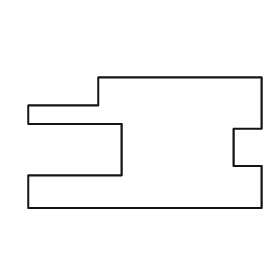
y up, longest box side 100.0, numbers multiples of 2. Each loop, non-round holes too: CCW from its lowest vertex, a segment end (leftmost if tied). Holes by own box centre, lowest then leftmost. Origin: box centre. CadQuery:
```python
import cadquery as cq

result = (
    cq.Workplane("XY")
    .moveTo(-50.0, -28.0)
    .lineTo(50.0, -28.0)
    .lineTo(50.0, -10.0)
    .lineTo(38.0, -10.0)
    .lineTo(38.0, 6.0)
    .lineTo(50.0, 6.0)
    .lineTo(50.0, 28.0)
    .lineTo(-20.0, 28.0)
    .lineTo(-20.0, 16.0)
    .lineTo(-50.0, 16.0)
    .lineTo(-50.0, 8.0)
    .lineTo(-10.0, 8.0)
    .lineTo(-10.0, -14.0)
    .lineTo(-50.0, -14.0)
    .close()
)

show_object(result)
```